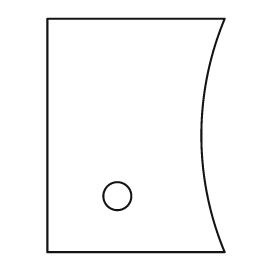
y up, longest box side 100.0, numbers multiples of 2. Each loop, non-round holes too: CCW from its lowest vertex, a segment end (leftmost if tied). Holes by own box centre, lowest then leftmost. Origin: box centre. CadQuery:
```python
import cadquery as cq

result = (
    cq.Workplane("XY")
    .moveTo(-38.0, -50.0)
    .lineTo(38.0, -50.0)
    .threePointArc((28.0, 0.0), (38.0, 50.0))
    .lineTo(-38.0, 50.0)
    .close()
    .moveTo(-8.0, -26.0)
    .circle(6.0)
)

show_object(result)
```